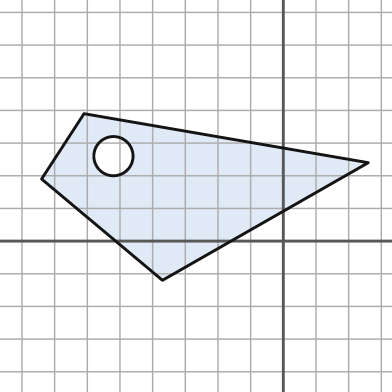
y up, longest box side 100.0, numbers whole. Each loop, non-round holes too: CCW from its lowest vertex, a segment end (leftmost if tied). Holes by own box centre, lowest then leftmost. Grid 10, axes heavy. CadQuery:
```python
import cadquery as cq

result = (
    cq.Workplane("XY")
    .moveTo(-37.0, -12.0)
    .lineTo(26.0, 24.0)
    .lineTo(-61.0, 39.0)
    .lineTo(-74.0, 19.0)
    .close()
    .moveTo(-52.0, 26.0)
    .circle(6.0)
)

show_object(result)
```